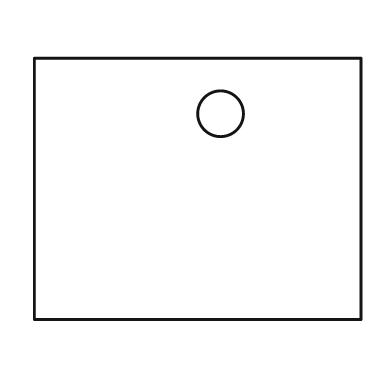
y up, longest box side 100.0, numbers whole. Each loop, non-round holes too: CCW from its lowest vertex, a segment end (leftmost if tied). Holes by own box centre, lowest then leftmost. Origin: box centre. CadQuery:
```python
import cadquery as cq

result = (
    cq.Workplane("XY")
    .moveTo(-50.0, -40.0)
    .lineTo(50.0, -40.0)
    .lineTo(50.0, 40.0)
    .lineTo(-50.0, 40.0)
    .close()
    .moveTo(7.0, 23.0)
    .circle(7.0)
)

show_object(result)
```